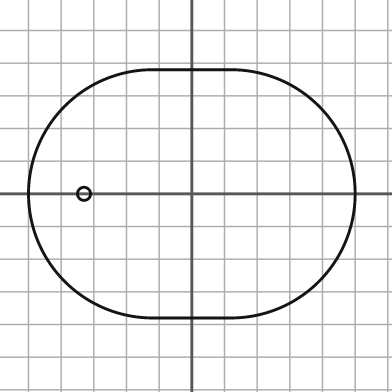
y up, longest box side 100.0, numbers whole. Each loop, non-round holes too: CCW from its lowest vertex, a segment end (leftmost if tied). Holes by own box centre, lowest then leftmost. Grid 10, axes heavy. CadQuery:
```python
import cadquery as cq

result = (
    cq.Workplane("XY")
    .moveTo(-12.0, -38.0)
    .lineTo(12.0, -38.0)
    .threePointArc((50.0, 0.0), (12.0, 38.0))
    .lineTo(-12.0, 38.0)
    .threePointArc((-50.0, 0.0), (-12.0, -38.0))
    .close()
    .moveTo(-33.0, 0.0)
    .circle(2.0)
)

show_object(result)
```